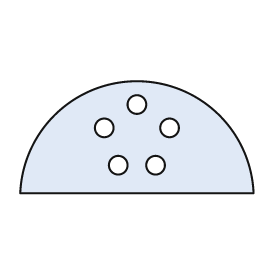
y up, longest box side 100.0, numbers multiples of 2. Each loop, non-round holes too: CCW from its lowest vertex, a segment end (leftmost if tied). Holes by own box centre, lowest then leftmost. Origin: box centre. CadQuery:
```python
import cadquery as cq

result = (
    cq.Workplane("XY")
    .moveTo(-50.0, -24.0)
    .lineTo(50.0, -24.0)
    .threePointArc((0.0, 24.0), (-50.0, -24.0))
    .close()
    .moveTo(-8.0, -12.0)
    .circle(4.0)
    .moveTo(8.0, -12.0)
    .circle(4.0)
    .moveTo(-14.0, 4.0)
    .circle(4.0)
    .moveTo(14.0, 4.0)
    .circle(4.0)
    .moveTo(0.0, 14.0)
    .circle(4.0)
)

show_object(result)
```